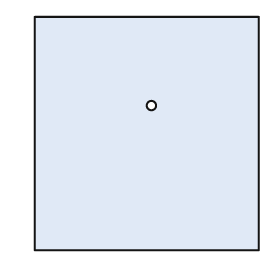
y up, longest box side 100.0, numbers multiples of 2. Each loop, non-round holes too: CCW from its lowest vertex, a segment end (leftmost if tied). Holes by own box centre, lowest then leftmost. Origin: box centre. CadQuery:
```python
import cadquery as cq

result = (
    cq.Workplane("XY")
    .moveTo(-48.0, -50.0)
    .lineTo(48.0, -50.0)
    .lineTo(48.0, 50.0)
    .lineTo(-48.0, 50.0)
    .close()
    .moveTo(2.0, 12.0)
    .circle(2.0)
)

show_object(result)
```